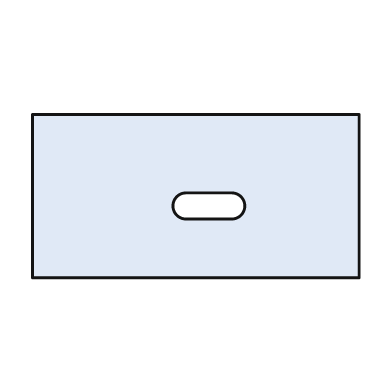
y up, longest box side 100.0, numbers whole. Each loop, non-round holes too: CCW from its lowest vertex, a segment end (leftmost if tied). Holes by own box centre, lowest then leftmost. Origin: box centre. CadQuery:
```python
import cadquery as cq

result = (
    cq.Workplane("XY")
    .moveTo(-50.0, -25.0)
    .lineTo(50.0, -25.0)
    .lineTo(50.0, 25.0)
    .lineTo(-50.0, 25.0)
    .close()
    .moveTo(-3.0, -7.0)
    .lineTo(11.0, -7.0)
    .threePointArc((15.0, -3.0), (11.0, 1.0))
    .lineTo(-3.0, 1.0)
    .threePointArc((-7.0, -3.0), (-3.0, -7.0))
    .close()
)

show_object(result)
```